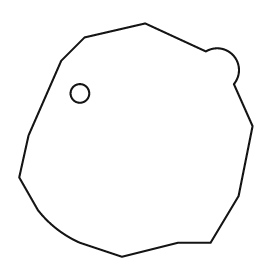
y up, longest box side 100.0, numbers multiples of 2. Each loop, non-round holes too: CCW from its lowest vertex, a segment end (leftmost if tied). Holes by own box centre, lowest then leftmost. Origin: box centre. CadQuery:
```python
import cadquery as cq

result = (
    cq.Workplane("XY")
    .moveTo(-6.0, -50.0)
    .lineTo(18.0, -44.0)
    .lineTo(32.0, -44.0)
    .lineTo(44.0, -24.0)
    .lineTo(50.0, 6.0)
    .lineTo(42.0, 24.0)
    .threePointArc((42.0, 36.0), (30.0, 38.0))
    .lineTo(4.0, 50.0)
    .lineTo(-22.0, 44.0)
    .lineTo(-32.0, 34.0)
    .lineTo(-46.0, 2.0)
    .lineTo(-50.0, -16.0)
    .lineTo(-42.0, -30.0)
    .threePointArc((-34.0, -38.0), (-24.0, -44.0))
    .close()
    .moveTo(-24.0, 20.0)
    .circle(4.0)
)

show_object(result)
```